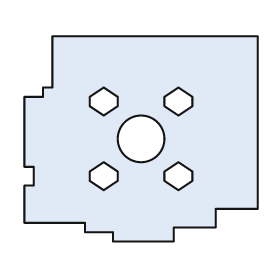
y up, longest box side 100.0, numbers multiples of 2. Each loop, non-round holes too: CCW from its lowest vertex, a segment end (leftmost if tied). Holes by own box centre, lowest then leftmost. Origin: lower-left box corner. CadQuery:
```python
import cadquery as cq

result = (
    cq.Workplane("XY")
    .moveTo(38.0, 0.0)
    .lineTo(64.0, 0.0)
    .lineTo(64.0, 6.0)
    .lineTo(82.0, 6.0)
    .lineTo(82.0, 14.0)
    .lineTo(100.0, 14.0)
    .lineTo(100.0, 88.0)
    .lineTo(12.0, 88.0)
    .lineTo(12.0, 66.0)
    .lineTo(8.0, 66.0)
    .lineTo(8.0, 62.0)
    .lineTo(0.0, 62.0)
    .lineTo(0.0, 32.0)
    .lineTo(4.0, 32.0)
    .lineTo(4.0, 24.0)
    .lineTo(0.0, 24.0)
    .lineTo(0.0, 8.0)
    .lineTo(26.0, 8.0)
    .lineTo(26.0, 4.0)
    .lineTo(38.0, 4.0)
    .close()
    .moveTo(34.0, 22.0)
    .lineTo(40.0, 26.0)
    .lineTo(40.0, 30.0)
    .lineTo(34.0, 34.0)
    .lineTo(28.0, 30.0)
    .lineTo(28.0, 26.0)
    .close()
    .moveTo(66.0, 22.0)
    .lineTo(72.0, 26.0)
    .lineTo(72.0, 30.0)
    .lineTo(66.0, 34.0)
    .lineTo(60.0, 30.0)
    .lineTo(60.0, 26.0)
    .close()
    .moveTo(50.0, 44.0)
    .circle(10.0)
    .moveTo(34.0, 54.0)
    .lineTo(40.0, 58.0)
    .lineTo(40.0, 62.0)
    .lineTo(34.0, 66.0)
    .lineTo(28.0, 62.0)
    .lineTo(28.0, 58.0)
    .close()
    .moveTo(66.0, 54.0)
    .lineTo(72.0, 58.0)
    .lineTo(72.0, 62.0)
    .lineTo(66.0, 66.0)
    .lineTo(60.0, 62.0)
    .lineTo(60.0, 58.0)
    .close()
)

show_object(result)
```